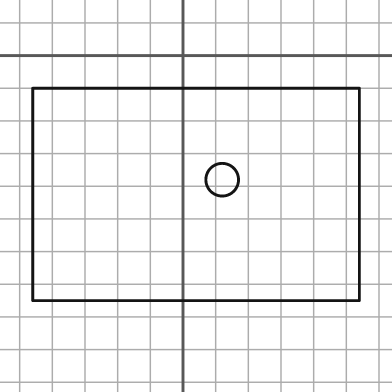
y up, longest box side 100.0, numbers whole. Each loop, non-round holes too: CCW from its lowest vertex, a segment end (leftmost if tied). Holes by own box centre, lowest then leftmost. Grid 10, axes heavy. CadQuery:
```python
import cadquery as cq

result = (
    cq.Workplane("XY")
    .moveTo(-46.0, -75.0)
    .lineTo(54.0, -75.0)
    .lineTo(54.0, -10.0)
    .lineTo(-46.0, -10.0)
    .close()
    .moveTo(12.0, -38.0)
    .circle(5.0)
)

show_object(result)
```